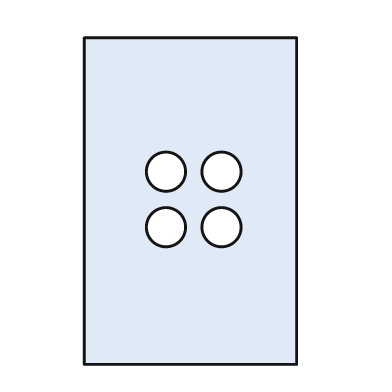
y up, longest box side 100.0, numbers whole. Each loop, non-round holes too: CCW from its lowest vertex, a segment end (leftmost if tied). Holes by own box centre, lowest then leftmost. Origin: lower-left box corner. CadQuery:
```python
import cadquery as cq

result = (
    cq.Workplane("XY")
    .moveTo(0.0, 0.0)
    .lineTo(65.0, 0.0)
    .lineTo(65.0, 100.0)
    .lineTo(0.0, 100.0)
    .close()
    .moveTo(25.0, 42.0)
    .circle(6.0)
    .moveTo(42.0, 42.0)
    .circle(6.0)
    .moveTo(25.0, 59.0)
    .circle(6.0)
    .moveTo(42.0, 59.0)
    .circle(6.0)
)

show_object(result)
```